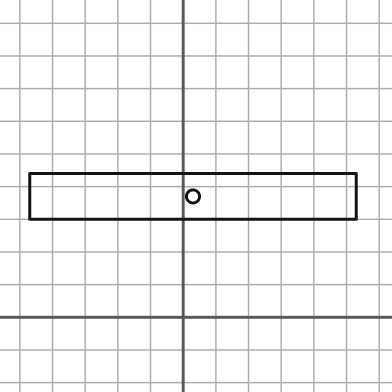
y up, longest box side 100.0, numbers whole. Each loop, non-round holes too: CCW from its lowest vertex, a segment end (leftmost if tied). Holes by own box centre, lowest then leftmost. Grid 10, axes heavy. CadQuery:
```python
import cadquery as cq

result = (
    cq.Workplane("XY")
    .moveTo(-47.0, 30.0)
    .lineTo(53.0, 30.0)
    .lineTo(53.0, 44.0)
    .lineTo(-47.0, 44.0)
    .close()
    .moveTo(3.0, 37.0)
    .circle(2.0)
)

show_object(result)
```